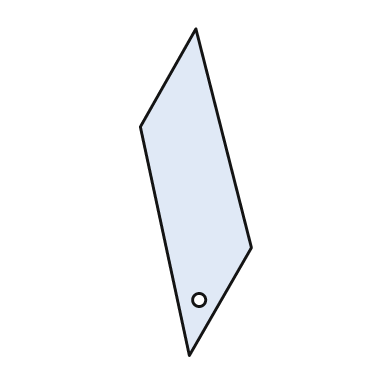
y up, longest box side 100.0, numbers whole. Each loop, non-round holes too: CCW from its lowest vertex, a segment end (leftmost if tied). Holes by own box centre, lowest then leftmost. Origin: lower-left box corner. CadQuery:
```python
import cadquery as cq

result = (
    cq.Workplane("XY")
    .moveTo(15.0, 0.0)
    .lineTo(34.0, 33.0)
    .lineTo(17.0, 100.0)
    .lineTo(0.0, 70.0)
    .close()
    .moveTo(18.0, 17.0)
    .circle(2.0)
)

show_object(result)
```